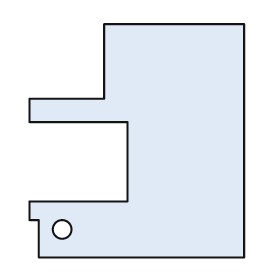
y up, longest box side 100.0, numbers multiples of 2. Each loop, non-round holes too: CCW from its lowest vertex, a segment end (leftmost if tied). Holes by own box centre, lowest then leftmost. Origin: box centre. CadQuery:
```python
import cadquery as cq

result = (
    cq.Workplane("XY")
    .moveTo(-42.0, -50.0)
    .lineTo(46.0, -50.0)
    .lineTo(46.0, 50.0)
    .lineTo(-14.0, 50.0)
    .lineTo(-14.0, 18.0)
    .lineTo(-46.0, 18.0)
    .lineTo(-46.0, 8.0)
    .lineTo(-4.0, 8.0)
    .lineTo(-4.0, -26.0)
    .lineTo(-46.0, -26.0)
    .lineTo(-46.0, -34.0)
    .lineTo(-42.0, -34.0)
    .close()
    .moveTo(-32.0, -38.0)
    .circle(4.0)
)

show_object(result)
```